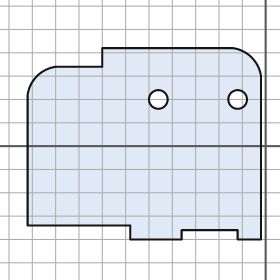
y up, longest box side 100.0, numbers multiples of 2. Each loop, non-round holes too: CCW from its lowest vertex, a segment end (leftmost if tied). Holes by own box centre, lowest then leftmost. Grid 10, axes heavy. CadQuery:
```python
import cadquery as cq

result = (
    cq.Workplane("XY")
    .moveTo(-58.0, -40.0)
    .lineTo(-36.0, -40.0)
    .lineTo(-36.0, -36.0)
    .lineTo(-12.0, -36.0)
    .lineTo(-12.0, -40.0)
    .lineTo(-2.0, -40.0)
    .lineTo(-2.0, 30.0)
    .threePointArc((-6.0, 38.0), (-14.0, 42.0))
    .lineTo(-70.0, 42.0)
    .lineTo(-70.0, 34.0)
    .lineTo(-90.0, 34.0)
    .threePointArc((-98.0, 30.0), (-102.0, 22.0))
    .lineTo(-102.0, -34.0)
    .lineTo(-58.0, -34.0)
    .close()
    .moveTo(-46.0, 20.0)
    .circle(4.0)
    .moveTo(-12.0, 20.0)
    .circle(4.0)
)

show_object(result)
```